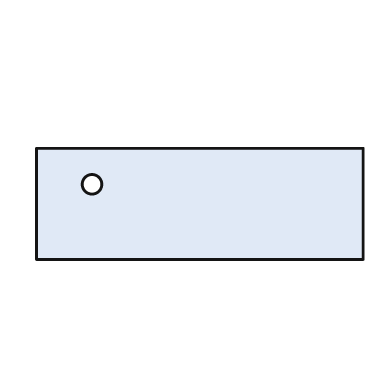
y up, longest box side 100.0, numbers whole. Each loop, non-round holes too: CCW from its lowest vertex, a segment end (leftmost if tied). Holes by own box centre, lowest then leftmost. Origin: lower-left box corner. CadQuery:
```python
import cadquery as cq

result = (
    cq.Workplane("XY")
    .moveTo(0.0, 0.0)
    .lineTo(100.0, 0.0)
    .lineTo(100.0, 34.0)
    .lineTo(0.0, 34.0)
    .close()
    .moveTo(17.0, 23.0)
    .circle(3.0)
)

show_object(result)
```